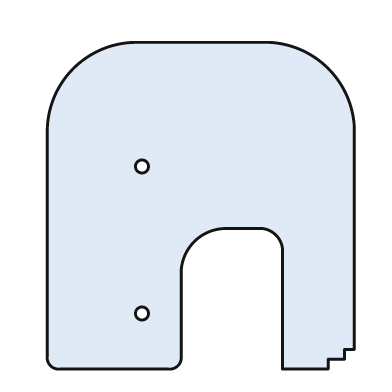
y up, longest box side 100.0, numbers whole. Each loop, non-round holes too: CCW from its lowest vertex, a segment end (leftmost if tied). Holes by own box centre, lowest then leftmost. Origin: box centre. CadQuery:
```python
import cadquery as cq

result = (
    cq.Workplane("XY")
    .moveTo(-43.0, -50.0)
    .lineTo(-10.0, -50.0)
    .threePointArc((-7.0, -49.0), (-6.0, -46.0))
    .lineTo(-6.0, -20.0)
    .threePointArc((-2.0, -11.0), (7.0, -7.0))
    .lineTo(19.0, -7.0)
    .threePointArc((23.0, -9.0), (25.0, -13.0))
    .lineTo(25.0, -50.0)
    .lineTo(39.0, -50.0)
    .lineTo(39.0, -47.0)
    .lineTo(44.0, -47.0)
    .lineTo(44.0, -44.0)
    .lineTo(47.0, -44.0)
    .lineTo(47.0, 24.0)
    .threePointArc((39.0, 42.0), (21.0, 50.0))
    .lineTo(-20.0, 50.0)
    .threePointArc((-39.0, 42.0), (-47.0, 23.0))
    .lineTo(-47.0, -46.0)
    .threePointArc((-46.0, -49.0), (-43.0, -50.0))
    .close()
    .moveTo(-18.0, -33.0)
    .circle(2.0)
    .moveTo(-18.0, 12.0)
    .circle(2.0)
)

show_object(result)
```